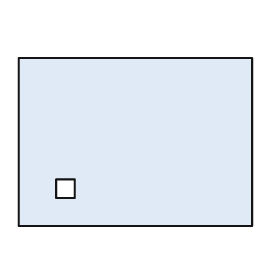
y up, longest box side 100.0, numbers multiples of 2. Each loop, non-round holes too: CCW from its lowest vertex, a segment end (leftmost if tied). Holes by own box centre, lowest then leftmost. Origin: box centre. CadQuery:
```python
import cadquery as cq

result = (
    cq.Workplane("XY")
    .moveTo(-50.0, -36.0)
    .lineTo(50.0, -36.0)
    .lineTo(50.0, 36.0)
    .lineTo(-50.0, 36.0)
    .close()
    .moveTo(-34.0, -24.0)
    .lineTo(-26.0, -24.0)
    .lineTo(-26.0, -16.0)
    .lineTo(-34.0, -16.0)
    .close()
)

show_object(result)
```